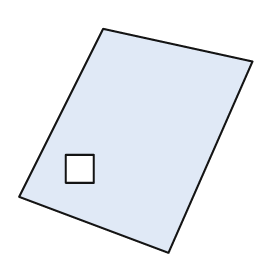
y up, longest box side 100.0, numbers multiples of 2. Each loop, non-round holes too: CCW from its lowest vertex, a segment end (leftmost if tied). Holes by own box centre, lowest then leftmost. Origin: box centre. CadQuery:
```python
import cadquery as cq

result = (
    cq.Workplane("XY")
    .moveTo(14.0, -48.0)
    .lineTo(50.0, 34.0)
    .lineTo(-14.0, 48.0)
    .lineTo(-50.0, -24.0)
    .close()
    .moveTo(-30.0, -18.0)
    .lineTo(-18.0, -18.0)
    .lineTo(-18.0, -6.0)
    .lineTo(-30.0, -6.0)
    .close()
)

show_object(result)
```